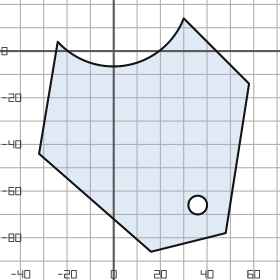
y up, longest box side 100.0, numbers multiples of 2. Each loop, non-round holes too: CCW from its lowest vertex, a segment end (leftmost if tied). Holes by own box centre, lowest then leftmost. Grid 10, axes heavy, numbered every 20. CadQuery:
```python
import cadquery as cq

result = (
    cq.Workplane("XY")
    .moveTo(16.0, -86.0)
    .lineTo(48.0, -78.0)
    .lineTo(58.0, -14.0)
    .lineTo(30.0, 14.0)
    .threePointArc((6.0, -6.0), (-24.0, 4.0))
    .lineTo(-32.0, -44.0)
    .close()
    .moveTo(36.0, -66.0)
    .circle(4.0)
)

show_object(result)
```